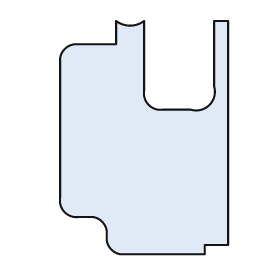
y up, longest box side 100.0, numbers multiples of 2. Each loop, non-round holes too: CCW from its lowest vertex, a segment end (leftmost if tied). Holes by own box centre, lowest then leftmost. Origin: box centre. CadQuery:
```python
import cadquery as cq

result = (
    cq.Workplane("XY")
    .moveTo(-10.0, -50.0)
    .lineTo(26.0, -50.0)
    .lineTo(26.0, -46.0)
    .lineTo(36.0, -46.0)
    .lineTo(36.0, 50.0)
    .lineTo(30.0, 50.0)
    .lineTo(30.0, 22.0)
    .threePointArc((28.0, 14.0), (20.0, 12.0))
    .lineTo(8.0, 12.0)
    .threePointArc((2.0, 14.0), (0.0, 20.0))
    .lineTo(0.0, 50.0)
    .threePointArc((-6.0, 48.0), (-12.0, 50.0))
    .lineTo(-12.0, 40.0)
    .lineTo(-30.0, 40.0)
    .threePointArc((-34.0, 38.0), (-36.0, 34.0))
    .lineTo(-36.0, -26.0)
    .threePointArc((-34.0, -32.0), (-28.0, -34.0))
    .lineTo(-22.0, -34.0)
    .threePointArc((-18.0, -36.0), (-16.0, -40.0))
    .lineTo(-16.0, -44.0)
    .threePointArc((-14.0, -48.0), (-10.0, -50.0))
    .close()
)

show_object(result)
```